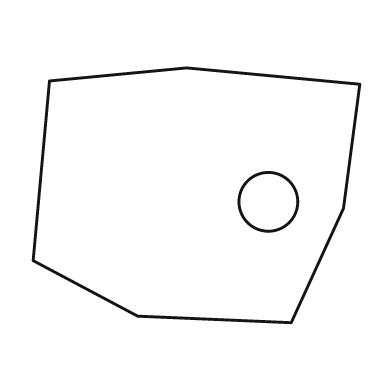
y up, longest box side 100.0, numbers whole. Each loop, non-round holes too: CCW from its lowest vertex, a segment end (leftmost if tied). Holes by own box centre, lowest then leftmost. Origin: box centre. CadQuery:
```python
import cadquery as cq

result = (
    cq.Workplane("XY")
    .moveTo(29.0, -39.0)
    .lineTo(45.0, -4.0)
    .lineTo(50.0, 34.0)
    .lineTo(-3.0, 39.0)
    .lineTo(-45.0, 35.0)
    .lineTo(-50.0, -20.0)
    .lineTo(-18.0, -37.0)
    .close()
    .moveTo(22.0, -2.0)
    .circle(9.0)
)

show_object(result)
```